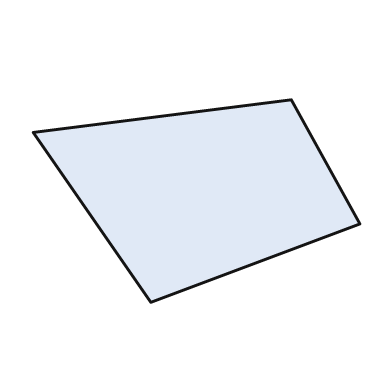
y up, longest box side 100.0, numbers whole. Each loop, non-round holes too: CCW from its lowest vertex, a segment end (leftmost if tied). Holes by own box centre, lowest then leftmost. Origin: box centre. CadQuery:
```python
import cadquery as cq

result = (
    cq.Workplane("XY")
    .moveTo(-14.0, -31.0)
    .lineTo(50.0, -7.0)
    .lineTo(29.0, 31.0)
    .lineTo(-50.0, 21.0)
    .close()
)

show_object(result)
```